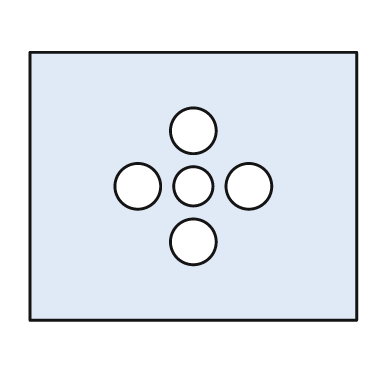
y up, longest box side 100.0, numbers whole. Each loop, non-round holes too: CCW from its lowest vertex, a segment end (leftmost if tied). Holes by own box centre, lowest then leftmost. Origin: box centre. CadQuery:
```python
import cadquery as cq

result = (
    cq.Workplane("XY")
    .moveTo(-50.0, -41.0)
    .lineTo(50.0, -41.0)
    .lineTo(50.0, 41.0)
    .lineTo(-50.0, 41.0)
    .close()
    .moveTo(0.0, -17.0)
    .circle(7.0)
    .moveTo(-17.0, 0.0)
    .circle(7.0)
    .moveTo(0.0, 0.0)
    .circle(6.0)
    .moveTo(17.0, 0.0)
    .circle(7.0)
    .moveTo(0.0, 17.0)
    .circle(7.0)
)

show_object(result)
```